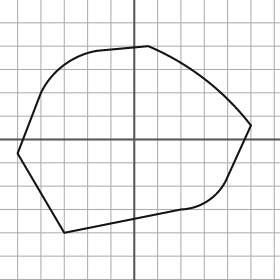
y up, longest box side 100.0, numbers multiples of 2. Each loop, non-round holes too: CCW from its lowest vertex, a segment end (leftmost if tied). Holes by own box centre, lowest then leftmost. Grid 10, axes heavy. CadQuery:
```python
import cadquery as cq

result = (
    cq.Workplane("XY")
    .moveTo(-30.0, -40.0)
    .lineTo(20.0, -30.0)
    .threePointArc((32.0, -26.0), (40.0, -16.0))
    .lineTo(50.0, 6.0)
    .threePointArc((30.0, 26.0), (6.0, 40.0))
    .lineTo(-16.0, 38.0)
    .threePointArc((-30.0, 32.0), (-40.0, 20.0))
    .lineTo(-50.0, -6.0)
    .close()
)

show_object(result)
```